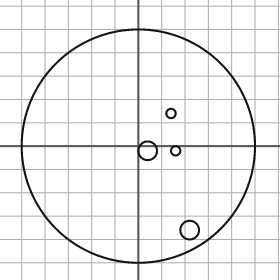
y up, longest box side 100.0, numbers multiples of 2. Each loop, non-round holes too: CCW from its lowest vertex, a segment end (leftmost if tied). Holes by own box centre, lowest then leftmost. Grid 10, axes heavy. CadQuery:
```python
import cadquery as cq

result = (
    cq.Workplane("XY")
    .moveTo(0.0, 0.0)
    .circle(50.0)
    .moveTo(22.0, -36.0)
    .circle(4.0)
    .moveTo(4.0, -2.0)
    .circle(4.0)
    .moveTo(16.0, -2.0)
    .circle(2.0)
    .moveTo(14.0, 14.0)
    .circle(2.0)
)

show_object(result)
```